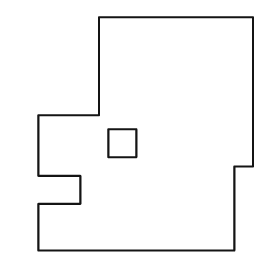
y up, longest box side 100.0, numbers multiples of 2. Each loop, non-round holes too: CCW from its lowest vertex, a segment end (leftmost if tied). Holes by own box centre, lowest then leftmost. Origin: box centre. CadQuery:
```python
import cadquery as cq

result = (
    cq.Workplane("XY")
    .moveTo(-46.0, -50.0)
    .lineTo(38.0, -50.0)
    .lineTo(38.0, -14.0)
    .lineTo(46.0, -14.0)
    .lineTo(46.0, 50.0)
    .lineTo(-20.0, 50.0)
    .lineTo(-20.0, 8.0)
    .lineTo(-46.0, 8.0)
    .lineTo(-46.0, -18.0)
    .lineTo(-28.0, -18.0)
    .lineTo(-28.0, -30.0)
    .lineTo(-46.0, -30.0)
    .close()
    .moveTo(-16.0, -10.0)
    .lineTo(-4.0, -10.0)
    .lineTo(-4.0, 2.0)
    .lineTo(-16.0, 2.0)
    .close()
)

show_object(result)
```